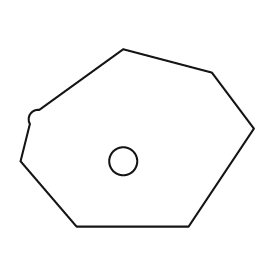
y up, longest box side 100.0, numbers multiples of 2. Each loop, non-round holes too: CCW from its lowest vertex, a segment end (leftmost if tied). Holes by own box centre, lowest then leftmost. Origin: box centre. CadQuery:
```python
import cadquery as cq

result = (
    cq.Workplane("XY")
    .moveTo(-26.0, -38.0)
    .lineTo(22.0, -38.0)
    .lineTo(50.0, 4.0)
    .lineTo(32.0, 28.0)
    .lineTo(-6.0, 38.0)
    .lineTo(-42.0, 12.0)
    .threePointArc((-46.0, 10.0), (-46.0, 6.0))
    .lineTo(-50.0, -10.0)
    .close()
    .moveTo(-6.0, -10.0)
    .circle(6.0)
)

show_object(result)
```